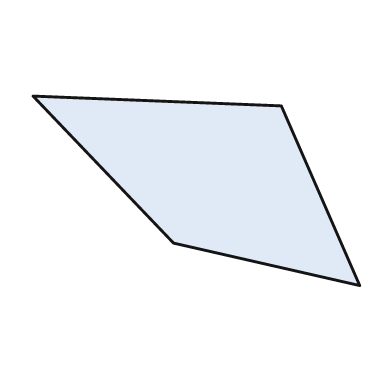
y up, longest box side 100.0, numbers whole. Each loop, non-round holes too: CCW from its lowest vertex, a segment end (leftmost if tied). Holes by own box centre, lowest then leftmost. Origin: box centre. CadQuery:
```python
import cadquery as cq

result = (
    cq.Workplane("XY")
    .moveTo(50.0, -29.0)
    .lineTo(26.0, 26.0)
    .lineTo(-50.0, 29.0)
    .lineTo(-7.0, -16.0)
    .close()
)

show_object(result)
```